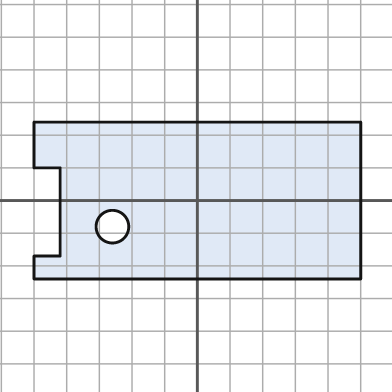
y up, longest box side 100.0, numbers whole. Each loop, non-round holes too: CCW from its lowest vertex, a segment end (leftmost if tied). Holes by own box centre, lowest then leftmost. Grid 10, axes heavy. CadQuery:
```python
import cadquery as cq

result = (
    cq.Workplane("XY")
    .moveTo(-50.0, -24.0)
    .lineTo(50.0, -24.0)
    .lineTo(50.0, 24.0)
    .lineTo(-50.0, 24.0)
    .lineTo(-50.0, 10.0)
    .lineTo(-42.0, 10.0)
    .lineTo(-42.0, -17.0)
    .lineTo(-50.0, -17.0)
    .close()
    .moveTo(-26.0, -8.0)
    .circle(5.0)
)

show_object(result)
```